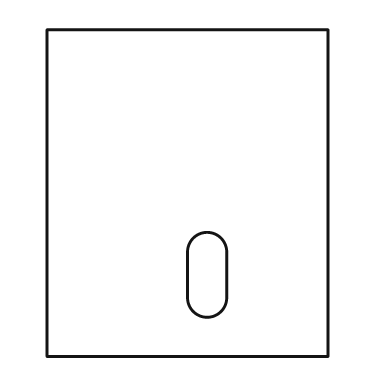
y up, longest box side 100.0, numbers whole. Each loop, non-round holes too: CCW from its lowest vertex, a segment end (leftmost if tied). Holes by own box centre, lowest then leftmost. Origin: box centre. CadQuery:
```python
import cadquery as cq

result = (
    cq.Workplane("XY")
    .moveTo(-43.0, -50.0)
    .lineTo(43.0, -50.0)
    .lineTo(43.0, 50.0)
    .lineTo(-43.0, 50.0)
    .close()
    .moveTo(0.0, -32.0)
    .threePointArc((6.0, -38.0), (12.0, -32.0))
    .lineTo(12.0, -18.0)
    .threePointArc((6.0, -12.0), (0.0, -18.0))
    .close()
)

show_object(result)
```